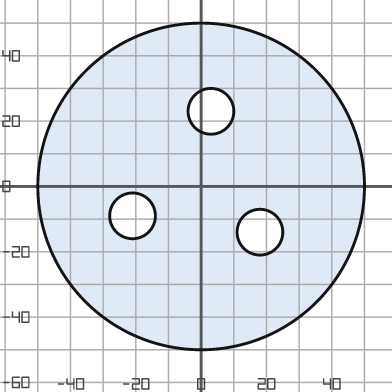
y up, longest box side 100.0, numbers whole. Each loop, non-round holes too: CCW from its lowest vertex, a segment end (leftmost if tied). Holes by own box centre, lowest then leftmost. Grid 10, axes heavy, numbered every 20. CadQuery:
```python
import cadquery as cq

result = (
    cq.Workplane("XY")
    .moveTo(0.0, 0.0)
    .circle(50.0)
    .moveTo(18.0, -14.0)
    .circle(7.0)
    .moveTo(-21.0, -9.0)
    .circle(7.0)
    .moveTo(3.0, 23.0)
    .circle(7.0)
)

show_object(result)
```